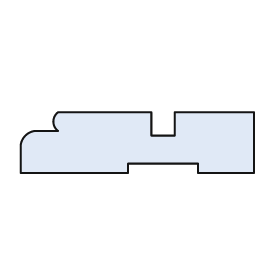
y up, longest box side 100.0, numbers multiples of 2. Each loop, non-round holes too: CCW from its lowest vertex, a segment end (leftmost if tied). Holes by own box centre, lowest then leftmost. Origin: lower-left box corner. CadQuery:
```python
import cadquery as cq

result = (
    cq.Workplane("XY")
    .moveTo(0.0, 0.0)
    .lineTo(46.0, 0.0)
    .lineTo(46.0, 4.0)
    .lineTo(76.0, 4.0)
    .lineTo(76.0, 0.0)
    .lineTo(100.0, 0.0)
    .lineTo(100.0, 26.0)
    .lineTo(66.0, 26.0)
    .lineTo(66.0, 16.0)
    .lineTo(56.0, 16.0)
    .lineTo(56.0, 26.0)
    .lineTo(16.0, 26.0)
    .threePointArc((14.0, 22.0), (16.0, 18.0))
    .lineTo(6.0, 18.0)
    .threePointArc((2.0, 16.0), (0.0, 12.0))
    .close()
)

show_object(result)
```